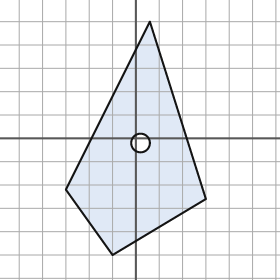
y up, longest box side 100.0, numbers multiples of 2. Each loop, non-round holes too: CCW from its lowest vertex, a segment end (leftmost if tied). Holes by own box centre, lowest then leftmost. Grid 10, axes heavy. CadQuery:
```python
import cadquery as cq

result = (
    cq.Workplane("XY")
    .moveTo(-10.0, -50.0)
    .lineTo(30.0, -26.0)
    .lineTo(6.0, 50.0)
    .lineTo(-30.0, -22.0)
    .close()
    .moveTo(2.0, -2.0)
    .circle(4.0)
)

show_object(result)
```